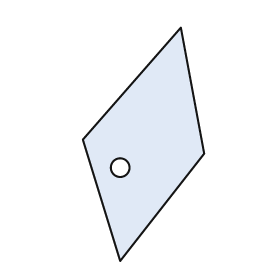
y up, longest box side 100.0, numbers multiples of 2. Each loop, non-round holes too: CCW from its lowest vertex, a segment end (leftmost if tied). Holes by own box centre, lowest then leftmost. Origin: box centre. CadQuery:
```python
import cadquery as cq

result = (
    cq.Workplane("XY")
    .moveTo(-10.0, -50.0)
    .lineTo(26.0, -4.0)
    .lineTo(16.0, 50.0)
    .lineTo(-26.0, 2.0)
    .close()
    .moveTo(-10.0, -10.0)
    .circle(4.0)
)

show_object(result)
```